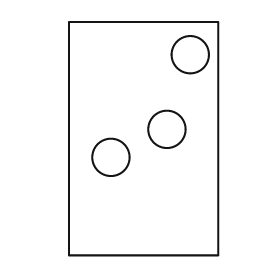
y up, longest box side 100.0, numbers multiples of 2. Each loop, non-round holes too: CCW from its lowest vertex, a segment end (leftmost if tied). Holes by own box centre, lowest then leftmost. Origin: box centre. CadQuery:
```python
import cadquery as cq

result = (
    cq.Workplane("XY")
    .moveTo(-32.0, -50.0)
    .lineTo(32.0, -50.0)
    .lineTo(32.0, 50.0)
    .lineTo(-32.0, 50.0)
    .close()
    .moveTo(-14.0, -8.0)
    .circle(8.0)
    .moveTo(10.0, 4.0)
    .circle(8.0)
    .moveTo(20.0, 36.0)
    .circle(8.0)
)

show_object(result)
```